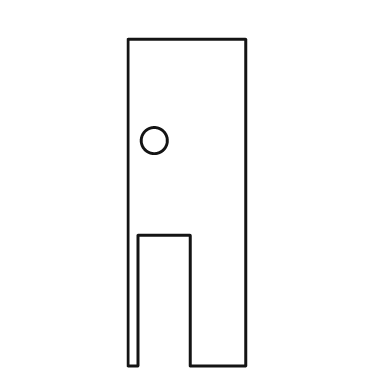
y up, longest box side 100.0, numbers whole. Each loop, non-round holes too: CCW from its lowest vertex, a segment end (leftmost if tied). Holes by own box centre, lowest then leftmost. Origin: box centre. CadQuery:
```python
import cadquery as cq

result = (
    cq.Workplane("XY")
    .moveTo(-18.0, -50.0)
    .lineTo(-15.0, -50.0)
    .lineTo(-15.0, -10.0)
    .lineTo(1.0, -10.0)
    .lineTo(1.0, -50.0)
    .lineTo(18.0, -50.0)
    .lineTo(18.0, 50.0)
    .lineTo(-18.0, 50.0)
    .close()
    .moveTo(-10.0, 19.0)
    .circle(4.0)
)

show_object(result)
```